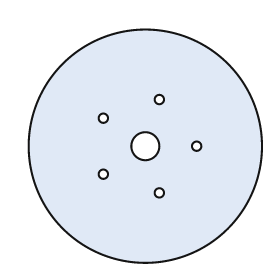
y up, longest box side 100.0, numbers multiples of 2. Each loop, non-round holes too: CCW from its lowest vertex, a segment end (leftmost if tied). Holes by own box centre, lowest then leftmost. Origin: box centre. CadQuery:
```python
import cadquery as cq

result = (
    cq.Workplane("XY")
    .moveTo(0.0, 0.0)
    .circle(50.0)
    .moveTo(6.0, -20.0)
    .circle(2.0)
    .moveTo(-18.0, -12.0)
    .circle(2.0)
    .moveTo(0.0, 0.0)
    .circle(6.0)
    .moveTo(22.0, 0.0)
    .circle(2.0)
    .moveTo(-18.0, 12.0)
    .circle(2.0)
    .moveTo(6.0, 20.0)
    .circle(2.0)
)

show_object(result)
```